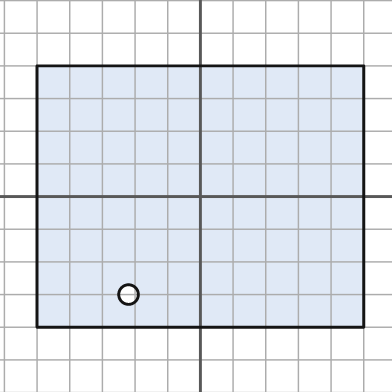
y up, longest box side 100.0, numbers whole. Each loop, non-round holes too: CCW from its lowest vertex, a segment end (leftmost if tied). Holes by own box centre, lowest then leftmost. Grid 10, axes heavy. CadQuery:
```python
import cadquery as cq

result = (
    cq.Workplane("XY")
    .moveTo(-50.0, -40.0)
    .lineTo(50.0, -40.0)
    .lineTo(50.0, 40.0)
    .lineTo(-50.0, 40.0)
    .close()
    .moveTo(-22.0, -30.0)
    .circle(3.0)
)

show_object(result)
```